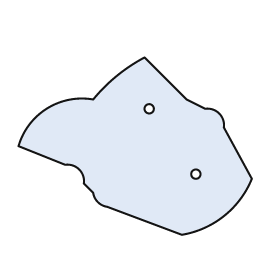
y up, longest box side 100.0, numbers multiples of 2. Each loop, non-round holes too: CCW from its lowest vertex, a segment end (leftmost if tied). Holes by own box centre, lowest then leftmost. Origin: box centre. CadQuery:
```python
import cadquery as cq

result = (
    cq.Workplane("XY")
    .moveTo(20.0, -38.0)
    .threePointArc((38.0, -30.0), (50.0, -14.0))
    .lineTo(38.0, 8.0)
    .threePointArc((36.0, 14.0), (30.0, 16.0))
    .lineTo(22.0, 20.0)
    .lineTo(4.0, 38.0)
    .threePointArc((-8.0, 30.0), (-18.0, 20.0))
    .threePointArc((-38.0, 16.0), (-50.0, 0.0))
    .lineTo(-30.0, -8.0)
    .threePointArc((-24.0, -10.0), (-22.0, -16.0))
    .lineTo(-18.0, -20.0)
    .threePointArc((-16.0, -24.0), (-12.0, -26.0))
    .close()
    .moveTo(26.0, -12.0)
    .circle(2.0)
    .moveTo(6.0, 16.0)
    .circle(2.0)
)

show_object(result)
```